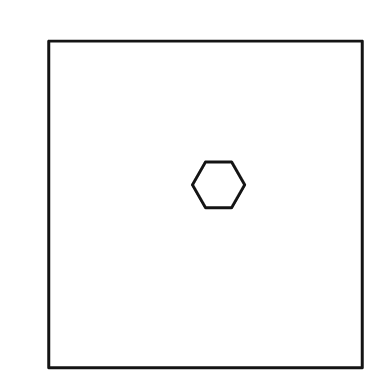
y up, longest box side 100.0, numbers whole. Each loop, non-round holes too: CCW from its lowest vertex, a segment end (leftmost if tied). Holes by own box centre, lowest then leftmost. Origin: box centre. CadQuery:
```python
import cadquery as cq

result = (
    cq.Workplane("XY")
    .moveTo(-48.0, -50.0)
    .lineTo(48.0, -50.0)
    .lineTo(48.0, 50.0)
    .lineTo(-48.0, 50.0)
    .close()
    .moveTo(0.0, -1.0)
    .lineTo(8.0, -1.0)
    .lineTo(12.0, 6.0)
    .lineTo(8.0, 13.0)
    .lineTo(0.0, 13.0)
    .lineTo(-4.0, 6.0)
    .close()
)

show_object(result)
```